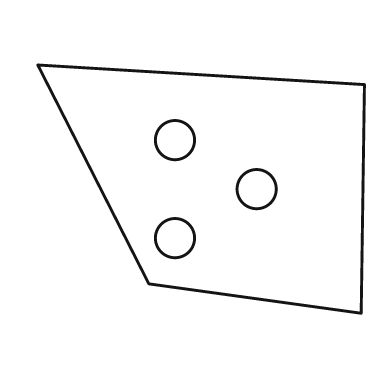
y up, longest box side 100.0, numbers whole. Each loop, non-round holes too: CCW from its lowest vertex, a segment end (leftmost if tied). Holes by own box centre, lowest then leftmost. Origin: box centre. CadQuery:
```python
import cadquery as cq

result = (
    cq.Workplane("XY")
    .moveTo(49.0, -38.0)
    .lineTo(50.0, 32.0)
    .lineTo(-50.0, 38.0)
    .lineTo(-16.0, -29.0)
    .close()
    .moveTo(-8.0, -15.0)
    .circle(6.0)
    .moveTo(17.0, 0.0)
    .circle(6.0)
    .moveTo(-8.0, 15.0)
    .circle(6.0)
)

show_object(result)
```